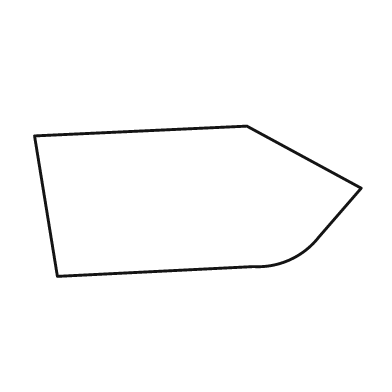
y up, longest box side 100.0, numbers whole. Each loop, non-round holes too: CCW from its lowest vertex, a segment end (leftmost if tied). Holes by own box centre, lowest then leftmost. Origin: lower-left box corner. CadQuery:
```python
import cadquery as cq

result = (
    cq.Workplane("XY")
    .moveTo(7.0, 0.0)
    .lineTo(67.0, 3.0)
    .threePointArc((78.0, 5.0), (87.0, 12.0))
    .lineTo(100.0, 27.0)
    .lineTo(65.0, 46.0)
    .lineTo(0.0, 43.0)
    .close()
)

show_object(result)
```